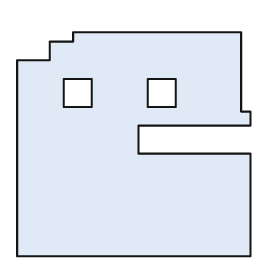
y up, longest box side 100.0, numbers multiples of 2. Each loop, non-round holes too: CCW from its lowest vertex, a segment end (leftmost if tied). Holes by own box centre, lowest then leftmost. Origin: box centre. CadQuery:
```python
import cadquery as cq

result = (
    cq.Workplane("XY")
    .moveTo(-50.0, -48.0)
    .lineTo(50.0, -48.0)
    .lineTo(50.0, -4.0)
    .lineTo(2.0, -4.0)
    .lineTo(2.0, 8.0)
    .lineTo(50.0, 8.0)
    .lineTo(50.0, 14.0)
    .lineTo(46.0, 14.0)
    .lineTo(46.0, 48.0)
    .lineTo(-26.0, 48.0)
    .lineTo(-26.0, 44.0)
    .lineTo(-36.0, 44.0)
    .lineTo(-36.0, 36.0)
    .lineTo(-50.0, 36.0)
    .close()
    .moveTo(-30.0, 16.0)
    .lineTo(-18.0, 16.0)
    .lineTo(-18.0, 28.0)
    .lineTo(-30.0, 28.0)
    .close()
    .moveTo(6.0, 16.0)
    .lineTo(18.0, 16.0)
    .lineTo(18.0, 28.0)
    .lineTo(6.0, 28.0)
    .close()
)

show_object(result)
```